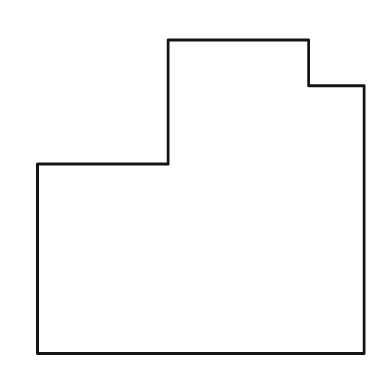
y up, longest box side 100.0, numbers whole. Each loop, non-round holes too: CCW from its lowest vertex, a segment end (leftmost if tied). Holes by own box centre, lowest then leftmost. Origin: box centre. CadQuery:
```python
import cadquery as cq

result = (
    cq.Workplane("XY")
    .moveTo(-50.0, -48.0)
    .lineTo(50.0, -48.0)
    .lineTo(50.0, 34.0)
    .lineTo(33.0, 34.0)
    .lineTo(33.0, 48.0)
    .lineTo(-10.0, 48.0)
    .lineTo(-10.0, 10.0)
    .lineTo(-50.0, 10.0)
    .close()
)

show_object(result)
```